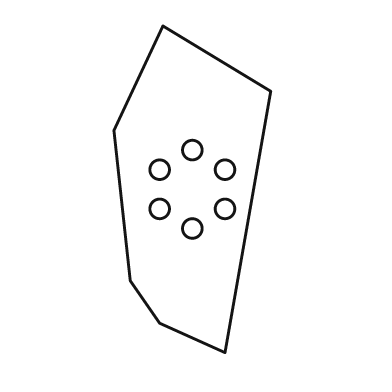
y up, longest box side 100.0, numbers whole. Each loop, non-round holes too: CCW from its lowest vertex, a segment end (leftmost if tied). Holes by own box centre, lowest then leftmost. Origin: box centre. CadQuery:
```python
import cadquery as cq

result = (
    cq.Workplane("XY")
    .moveTo(10.0, -50.0)
    .lineTo(24.0, 30.0)
    .lineTo(-9.0, 50.0)
    .lineTo(-24.0, 18.0)
    .lineTo(-19.0, -28.0)
    .lineTo(-10.0, -41.0)
    .close()
    .moveTo(0.0, -12.0)
    .circle(3.0)
    .moveTo(-10.0, -6.0)
    .circle(3.0)
    .moveTo(10.0, -6.0)
    .circle(3.0)
    .moveTo(-10.0, 6.0)
    .circle(3.0)
    .moveTo(10.0, 6.0)
    .circle(3.0)
    .moveTo(0.0, 12.0)
    .circle(3.0)
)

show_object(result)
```